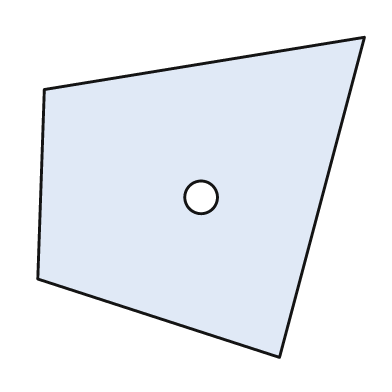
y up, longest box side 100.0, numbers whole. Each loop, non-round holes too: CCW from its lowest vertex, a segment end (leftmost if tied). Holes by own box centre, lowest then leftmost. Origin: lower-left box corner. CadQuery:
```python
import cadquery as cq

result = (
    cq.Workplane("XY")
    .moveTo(74.0, 0.0)
    .lineTo(100.0, 98.0)
    .lineTo(2.0, 82.0)
    .lineTo(0.0, 24.0)
    .close()
    .moveTo(50.0, 49.0)
    .circle(5.0)
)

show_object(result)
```